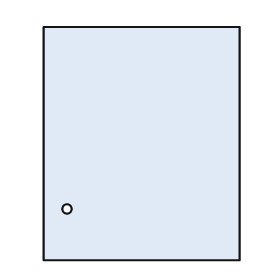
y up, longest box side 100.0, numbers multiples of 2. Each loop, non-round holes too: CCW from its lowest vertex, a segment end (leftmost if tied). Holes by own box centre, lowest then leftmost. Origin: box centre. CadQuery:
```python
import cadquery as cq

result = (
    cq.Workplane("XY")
    .moveTo(-42.0, -50.0)
    .lineTo(42.0, -50.0)
    .lineTo(42.0, 50.0)
    .lineTo(-42.0, 50.0)
    .close()
    .moveTo(-32.0, -28.0)
    .circle(2.0)
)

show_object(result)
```